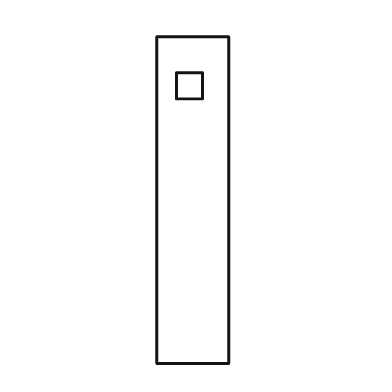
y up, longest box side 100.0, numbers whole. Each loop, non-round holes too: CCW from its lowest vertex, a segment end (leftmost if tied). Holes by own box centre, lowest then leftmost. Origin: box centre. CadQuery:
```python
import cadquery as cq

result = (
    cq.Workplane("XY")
    .moveTo(-11.0, -50.0)
    .lineTo(11.0, -50.0)
    .lineTo(11.0, 50.0)
    .lineTo(-11.0, 50.0)
    .close()
    .moveTo(-5.0, 31.0)
    .lineTo(3.0, 31.0)
    .lineTo(3.0, 39.0)
    .lineTo(-5.0, 39.0)
    .close()
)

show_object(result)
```